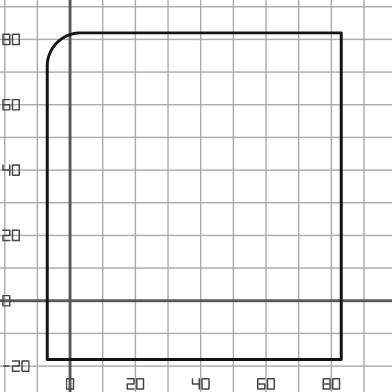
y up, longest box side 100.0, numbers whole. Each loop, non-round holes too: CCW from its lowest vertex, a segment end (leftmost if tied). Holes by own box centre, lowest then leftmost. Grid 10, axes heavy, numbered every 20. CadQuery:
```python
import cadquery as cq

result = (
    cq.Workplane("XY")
    .moveTo(-7.0, -18.0)
    .lineTo(83.0, -18.0)
    .lineTo(83.0, 82.0)
    .lineTo(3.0, 82.0)
    .threePointArc((-4.0, 79.0), (-7.0, 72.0))
    .close()
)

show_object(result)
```